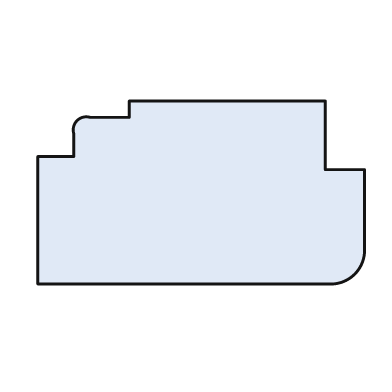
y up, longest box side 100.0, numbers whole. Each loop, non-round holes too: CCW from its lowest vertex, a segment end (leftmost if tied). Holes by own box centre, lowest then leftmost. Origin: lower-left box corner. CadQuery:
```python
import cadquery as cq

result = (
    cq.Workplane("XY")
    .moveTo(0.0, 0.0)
    .lineTo(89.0, 0.0)
    .threePointArc((97.0, 3.0), (100.0, 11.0))
    .lineTo(100.0, 35.0)
    .lineTo(88.0, 35.0)
    .lineTo(88.0, 56.0)
    .lineTo(28.0, 56.0)
    .lineTo(28.0, 51.0)
    .lineTo(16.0, 51.0)
    .threePointArc((12.0, 50.0), (11.0, 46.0))
    .lineTo(11.0, 39.0)
    .lineTo(0.0, 39.0)
    .close()
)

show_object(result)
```